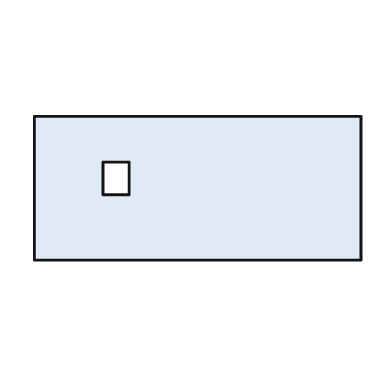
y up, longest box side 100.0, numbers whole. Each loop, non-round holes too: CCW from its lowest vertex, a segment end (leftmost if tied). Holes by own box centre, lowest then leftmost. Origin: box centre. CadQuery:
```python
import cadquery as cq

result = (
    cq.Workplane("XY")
    .moveTo(-50.0, -22.0)
    .lineTo(50.0, -22.0)
    .lineTo(50.0, 22.0)
    .lineTo(-50.0, 22.0)
    .close()
    .moveTo(-29.0, -2.0)
    .lineTo(-21.0, -2.0)
    .lineTo(-21.0, 8.0)
    .lineTo(-29.0, 8.0)
    .close()
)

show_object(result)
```